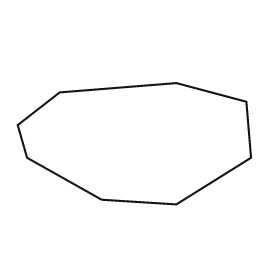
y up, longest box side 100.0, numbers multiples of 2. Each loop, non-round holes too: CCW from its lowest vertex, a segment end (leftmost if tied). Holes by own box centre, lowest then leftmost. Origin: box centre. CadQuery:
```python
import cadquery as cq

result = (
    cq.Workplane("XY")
    .moveTo(18.0, -26.0)
    .lineTo(50.0, -6.0)
    .lineTo(48.0, 18.0)
    .lineTo(18.0, 26.0)
    .lineTo(-32.0, 22.0)
    .lineTo(-50.0, 8.0)
    .lineTo(-46.0, -6.0)
    .lineTo(-14.0, -24.0)
    .close()
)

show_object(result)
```